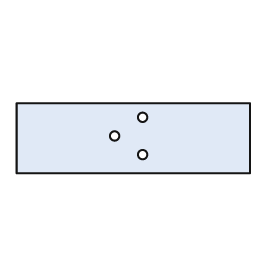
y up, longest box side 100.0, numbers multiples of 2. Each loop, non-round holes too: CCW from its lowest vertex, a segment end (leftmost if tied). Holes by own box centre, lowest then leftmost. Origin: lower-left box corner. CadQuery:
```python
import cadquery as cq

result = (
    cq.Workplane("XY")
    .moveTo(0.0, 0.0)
    .lineTo(100.0, 0.0)
    .lineTo(100.0, 30.0)
    .lineTo(0.0, 30.0)
    .close()
    .moveTo(54.0, 8.0)
    .circle(2.0)
    .moveTo(42.0, 16.0)
    .circle(2.0)
    .moveTo(54.0, 24.0)
    .circle(2.0)
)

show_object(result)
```